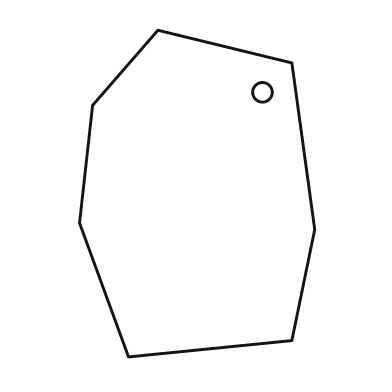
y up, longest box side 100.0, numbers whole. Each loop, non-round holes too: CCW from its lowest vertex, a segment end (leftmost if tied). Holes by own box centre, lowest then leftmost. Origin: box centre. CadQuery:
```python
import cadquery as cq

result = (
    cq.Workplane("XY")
    .moveTo(-21.0, -50.0)
    .lineTo(29.0, -45.0)
    .lineTo(36.0, -11.0)
    .lineTo(29.0, 40.0)
    .lineTo(-12.0, 50.0)
    .lineTo(-32.0, 27.0)
    .lineTo(-36.0, -9.0)
    .close()
    .moveTo(20.0, 31.0)
    .circle(3.0)
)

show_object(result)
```